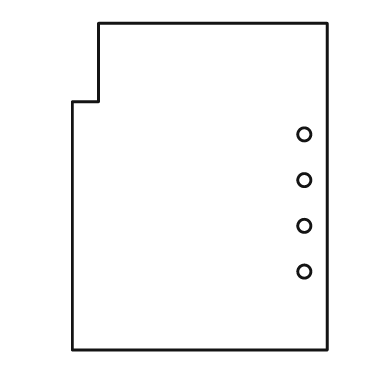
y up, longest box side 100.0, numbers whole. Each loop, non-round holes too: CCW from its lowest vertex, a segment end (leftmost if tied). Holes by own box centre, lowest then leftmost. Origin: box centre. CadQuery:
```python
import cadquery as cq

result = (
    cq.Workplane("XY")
    .moveTo(-39.0, -50.0)
    .lineTo(39.0, -50.0)
    .lineTo(39.0, 50.0)
    .lineTo(-31.0, 50.0)
    .lineTo(-31.0, 26.0)
    .lineTo(-39.0, 26.0)
    .close()
    .moveTo(32.0, -26.0)
    .circle(2.0)
    .moveTo(32.0, -12.0)
    .circle(2.0)
    .moveTo(32.0, 2.0)
    .circle(2.0)
    .moveTo(32.0, 16.0)
    .circle(2.0)
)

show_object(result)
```